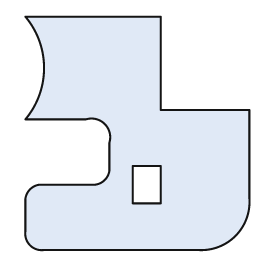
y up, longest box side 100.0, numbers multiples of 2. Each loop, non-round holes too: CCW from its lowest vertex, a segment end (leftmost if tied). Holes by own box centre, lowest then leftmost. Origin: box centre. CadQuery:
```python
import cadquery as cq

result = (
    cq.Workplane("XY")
    .moveTo(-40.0, -50.0)
    .lineTo(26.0, -50.0)
    .threePointArc((42.0, -44.0), (48.0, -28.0))
    .lineTo(48.0, 10.0)
    .lineTo(10.0, 10.0)
    .lineTo(10.0, 50.0)
    .lineTo(-48.0, 50.0)
    .threePointArc((-40.0, 28.0), (-48.0, 6.0))
    .lineTo(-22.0, 6.0)
    .threePointArc((-14.0, 4.0), (-12.0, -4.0))
    .lineTo(-12.0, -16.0)
    .threePointArc((-14.0, -20.0), (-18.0, -22.0))
    .lineTo(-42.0, -22.0)
    .threePointArc((-46.0, -24.0), (-48.0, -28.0))
    .lineTo(-48.0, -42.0)
    .threePointArc((-46.0, -48.0), (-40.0, -50.0))
    .close()
    .moveTo(-2.0, -30.0)
    .lineTo(10.0, -30.0)
    .lineTo(10.0, -14.0)
    .lineTo(-2.0, -14.0)
    .close()
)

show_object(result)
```